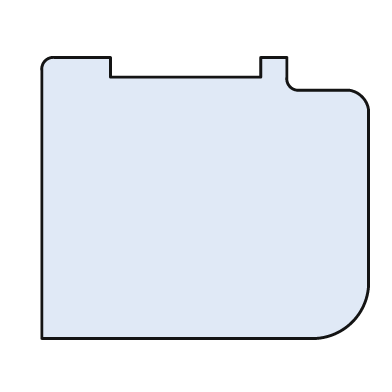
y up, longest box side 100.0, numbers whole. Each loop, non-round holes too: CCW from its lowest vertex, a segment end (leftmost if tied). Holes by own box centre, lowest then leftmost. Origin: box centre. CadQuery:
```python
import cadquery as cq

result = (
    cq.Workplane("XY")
    .moveTo(-50.0, -43.0)
    .lineTo(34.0, -43.0)
    .threePointArc((45.0, -38.0), (50.0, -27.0))
    .lineTo(50.0, 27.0)
    .threePointArc((48.0, 31.0), (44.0, 33.0))
    .lineTo(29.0, 33.0)
    .threePointArc((26.0, 34.0), (25.0, 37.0))
    .lineTo(25.0, 43.0)
    .lineTo(17.0, 43.0)
    .lineTo(17.0, 37.0)
    .lineTo(-29.0, 37.0)
    .lineTo(-29.0, 43.0)
    .lineTo(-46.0, 43.0)
    .threePointArc((-49.0, 42.0), (-50.0, 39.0))
    .close()
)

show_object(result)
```